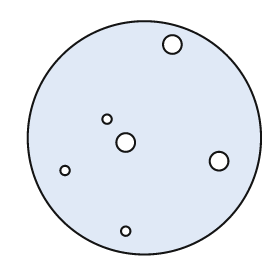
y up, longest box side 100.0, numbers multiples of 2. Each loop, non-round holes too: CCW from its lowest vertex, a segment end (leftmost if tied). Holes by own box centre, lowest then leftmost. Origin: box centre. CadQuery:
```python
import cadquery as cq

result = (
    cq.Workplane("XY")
    .moveTo(0.0, 0.0)
    .circle(50.0)
    .moveTo(-8.0, -40.0)
    .circle(2.0)
    .moveTo(-34.0, -14.0)
    .circle(2.0)
    .moveTo(32.0, -10.0)
    .circle(4.0)
    .moveTo(-8.0, -2.0)
    .circle(4.0)
    .moveTo(-16.0, 8.0)
    .circle(2.0)
    .moveTo(12.0, 40.0)
    .circle(4.0)
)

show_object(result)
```